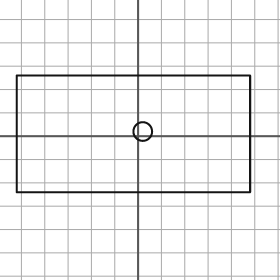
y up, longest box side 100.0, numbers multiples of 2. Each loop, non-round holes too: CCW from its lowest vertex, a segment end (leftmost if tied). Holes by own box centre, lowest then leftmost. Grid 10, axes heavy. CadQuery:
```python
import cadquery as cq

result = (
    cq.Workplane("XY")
    .moveTo(-52.0, -24.0)
    .lineTo(48.0, -24.0)
    .lineTo(48.0, 26.0)
    .lineTo(-52.0, 26.0)
    .close()
    .moveTo(2.0, 2.0)
    .circle(4.0)
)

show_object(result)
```